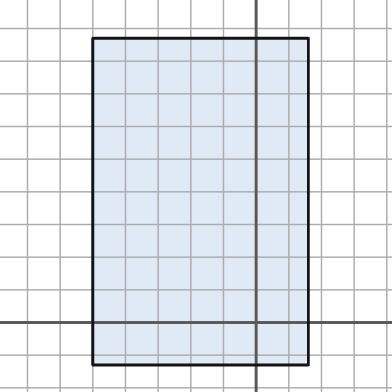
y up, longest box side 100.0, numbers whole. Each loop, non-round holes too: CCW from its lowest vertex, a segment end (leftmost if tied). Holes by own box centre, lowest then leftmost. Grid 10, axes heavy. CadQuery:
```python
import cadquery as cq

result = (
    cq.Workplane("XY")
    .moveTo(-50.0, -13.0)
    .lineTo(16.0, -13.0)
    .lineTo(16.0, 87.0)
    .lineTo(-50.0, 87.0)
    .close()
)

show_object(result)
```